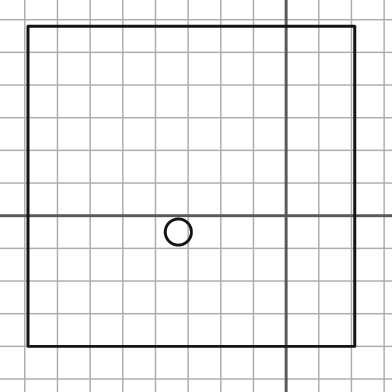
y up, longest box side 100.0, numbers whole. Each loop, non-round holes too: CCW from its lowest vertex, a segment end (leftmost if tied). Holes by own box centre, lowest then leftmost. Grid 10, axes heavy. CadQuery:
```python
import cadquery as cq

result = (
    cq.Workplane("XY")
    .moveTo(-79.0, -40.0)
    .lineTo(21.0, -40.0)
    .lineTo(21.0, 58.0)
    .lineTo(-79.0, 58.0)
    .close()
    .moveTo(-33.0, -5.0)
    .circle(4.0)
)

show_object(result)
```